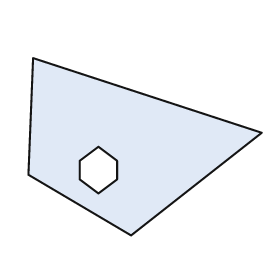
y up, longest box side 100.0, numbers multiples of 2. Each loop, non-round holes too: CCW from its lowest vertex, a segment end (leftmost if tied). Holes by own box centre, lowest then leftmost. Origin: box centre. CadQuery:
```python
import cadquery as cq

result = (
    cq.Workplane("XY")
    .moveTo(-6.0, -38.0)
    .lineTo(50.0, 6.0)
    .lineTo(-48.0, 38.0)
    .lineTo(-50.0, -12.0)
    .close()
    .moveTo(-20.0, -20.0)
    .lineTo(-12.0, -14.0)
    .lineTo(-12.0, -6.0)
    .lineTo(-20.0, 0.0)
    .lineTo(-28.0, -6.0)
    .lineTo(-28.0, -14.0)
    .close()
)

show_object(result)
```